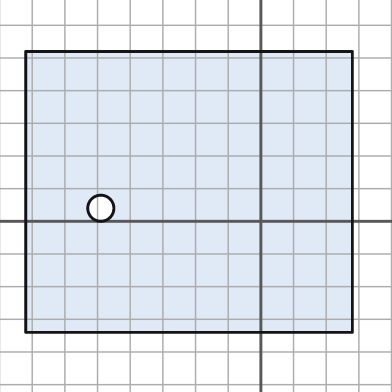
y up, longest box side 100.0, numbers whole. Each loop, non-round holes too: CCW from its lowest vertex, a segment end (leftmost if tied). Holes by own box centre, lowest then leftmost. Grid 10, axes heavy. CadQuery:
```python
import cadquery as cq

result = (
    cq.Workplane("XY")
    .moveTo(-72.0, -34.0)
    .lineTo(28.0, -34.0)
    .lineTo(28.0, 52.0)
    .lineTo(-72.0, 52.0)
    .close()
    .moveTo(-49.0, 4.0)
    .circle(4.0)
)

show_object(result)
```